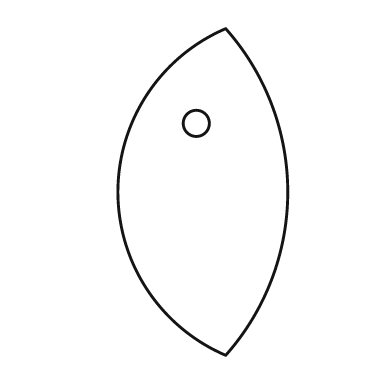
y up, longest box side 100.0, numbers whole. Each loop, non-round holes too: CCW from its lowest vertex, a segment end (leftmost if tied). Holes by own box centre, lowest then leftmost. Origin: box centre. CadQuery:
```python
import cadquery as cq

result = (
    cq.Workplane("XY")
    .moveTo(7.0, -50.0)
    .threePointArc((26.0, 0.0), (7.0, 50.0))
    .threePointArc((-26.0, 0.0), (7.0, -50.0))
    .close()
    .moveTo(-2.0, 21.0)
    .circle(4.0)
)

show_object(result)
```